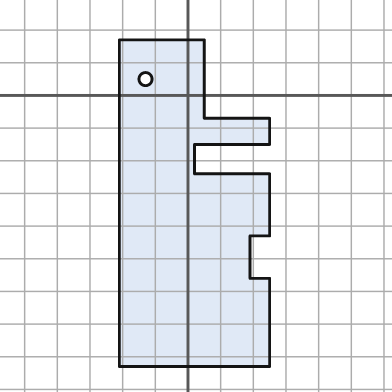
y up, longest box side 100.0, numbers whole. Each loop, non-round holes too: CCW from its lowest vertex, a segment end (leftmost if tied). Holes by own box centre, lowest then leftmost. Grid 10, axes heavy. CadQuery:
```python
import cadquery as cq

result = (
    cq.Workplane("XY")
    .moveTo(-21.0, -83.0)
    .lineTo(25.0, -83.0)
    .lineTo(25.0, -56.0)
    .lineTo(19.0, -56.0)
    .lineTo(19.0, -43.0)
    .lineTo(25.0, -43.0)
    .lineTo(25.0, -24.0)
    .lineTo(2.0, -24.0)
    .lineTo(2.0, -15.0)
    .lineTo(25.0, -15.0)
    .lineTo(25.0, -7.0)
    .lineTo(5.0, -7.0)
    .lineTo(5.0, 17.0)
    .lineTo(-21.0, 17.0)
    .close()
    .moveTo(-13.0, 5.0)
    .circle(2.0)
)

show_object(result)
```